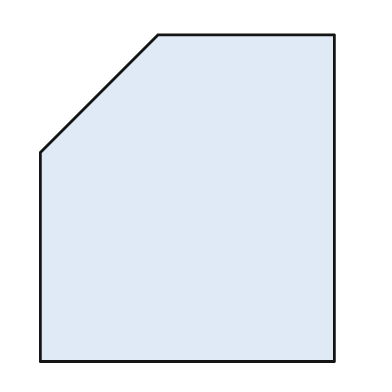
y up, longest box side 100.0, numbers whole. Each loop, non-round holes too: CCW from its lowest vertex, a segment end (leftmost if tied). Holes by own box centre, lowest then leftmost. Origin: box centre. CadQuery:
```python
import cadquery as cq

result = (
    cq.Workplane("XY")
    .moveTo(-45.0, -50.0)
    .lineTo(45.0, -50.0)
    .lineTo(45.0, 50.0)
    .lineTo(-9.0, 50.0)
    .lineTo(-45.0, 14.0)
    .close()
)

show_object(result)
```